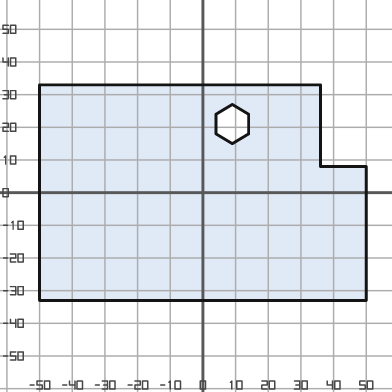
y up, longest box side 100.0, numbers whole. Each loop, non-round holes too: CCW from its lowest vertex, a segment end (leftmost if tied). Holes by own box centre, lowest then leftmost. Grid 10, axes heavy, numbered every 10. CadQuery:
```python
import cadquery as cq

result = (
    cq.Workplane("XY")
    .moveTo(-50.0, -33.0)
    .lineTo(50.0, -33.0)
    .lineTo(50.0, 8.0)
    .lineTo(36.0, 8.0)
    .lineTo(36.0, 33.0)
    .lineTo(-50.0, 33.0)
    .close()
    .moveTo(9.0, 15.0)
    .lineTo(14.0, 18.0)
    .lineTo(14.0, 24.0)
    .lineTo(9.0, 27.0)
    .lineTo(4.0, 24.0)
    .lineTo(4.0, 18.0)
    .close()
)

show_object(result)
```